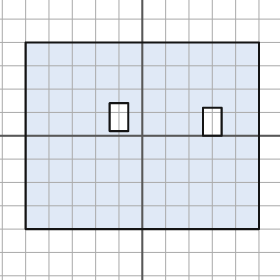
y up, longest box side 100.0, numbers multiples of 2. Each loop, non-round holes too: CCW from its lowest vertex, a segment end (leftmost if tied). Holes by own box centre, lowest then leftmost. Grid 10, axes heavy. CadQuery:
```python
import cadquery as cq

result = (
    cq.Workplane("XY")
    .moveTo(-50.0, -40.0)
    .lineTo(50.0, -40.0)
    .lineTo(50.0, 40.0)
    .lineTo(-50.0, 40.0)
    .close()
    .moveTo(26.0, 0.0)
    .lineTo(34.0, 0.0)
    .lineTo(34.0, 12.0)
    .lineTo(26.0, 12.0)
    .close()
    .moveTo(-14.0, 2.0)
    .lineTo(-6.0, 2.0)
    .lineTo(-6.0, 14.0)
    .lineTo(-14.0, 14.0)
    .close()
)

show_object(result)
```